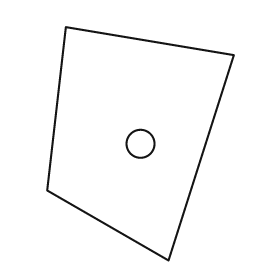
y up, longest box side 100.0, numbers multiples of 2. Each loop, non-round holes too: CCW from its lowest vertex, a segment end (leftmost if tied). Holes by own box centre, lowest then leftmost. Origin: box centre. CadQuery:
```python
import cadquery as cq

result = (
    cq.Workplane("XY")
    .moveTo(12.0, -50.0)
    .lineTo(40.0, 38.0)
    .lineTo(-32.0, 50.0)
    .lineTo(-40.0, -20.0)
    .close()
    .moveTo(0.0, 0.0)
    .circle(6.0)
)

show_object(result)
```